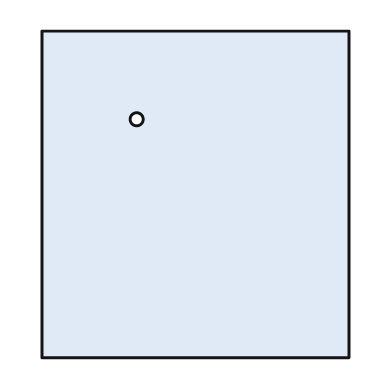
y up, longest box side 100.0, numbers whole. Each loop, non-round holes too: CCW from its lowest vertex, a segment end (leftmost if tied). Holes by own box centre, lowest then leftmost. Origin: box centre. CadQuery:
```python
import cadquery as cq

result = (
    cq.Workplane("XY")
    .moveTo(-47.0, -50.0)
    .lineTo(47.0, -50.0)
    .lineTo(47.0, 50.0)
    .lineTo(-47.0, 50.0)
    .close()
    .moveTo(-18.0, 23.0)
    .circle(2.0)
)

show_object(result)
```